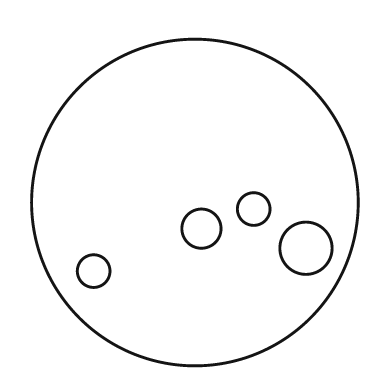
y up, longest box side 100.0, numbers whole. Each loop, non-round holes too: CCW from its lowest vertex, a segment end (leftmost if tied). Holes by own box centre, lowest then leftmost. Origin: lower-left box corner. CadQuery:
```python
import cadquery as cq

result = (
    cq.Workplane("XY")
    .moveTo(50.0, 50.0)
    .circle(50.0)
    .moveTo(19.0, 29.0)
    .circle(5.0)
    .moveTo(84.0, 36.0)
    .circle(8.0)
    .moveTo(52.0, 42.0)
    .circle(6.0)
    .moveTo(68.0, 48.0)
    .circle(5.0)
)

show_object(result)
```